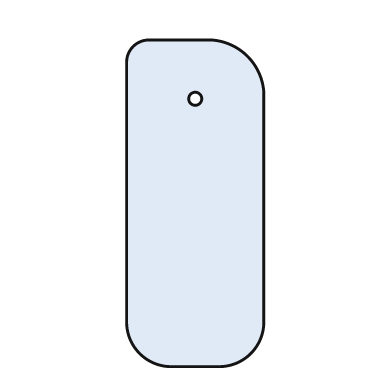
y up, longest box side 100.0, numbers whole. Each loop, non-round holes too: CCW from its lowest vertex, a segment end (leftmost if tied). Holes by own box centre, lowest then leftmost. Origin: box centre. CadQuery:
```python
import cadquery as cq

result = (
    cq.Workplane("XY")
    .moveTo(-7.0, -50.0)
    .lineTo(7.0, -50.0)
    .threePointArc((17.0, -46.0), (21.0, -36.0))
    .lineTo(21.0, 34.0)
    .threePointArc((16.0, 45.0), (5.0, 50.0))
    .lineTo(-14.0, 50.0)
    .threePointArc((-19.0, 48.0), (-21.0, 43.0))
    .lineTo(-21.0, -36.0)
    .threePointArc((-17.0, -46.0), (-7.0, -50.0))
    .close()
    .moveTo(0.0, 32.0)
    .circle(2.0)
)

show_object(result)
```